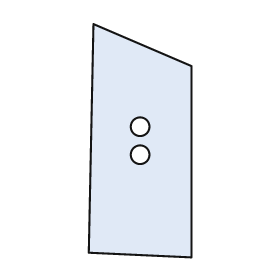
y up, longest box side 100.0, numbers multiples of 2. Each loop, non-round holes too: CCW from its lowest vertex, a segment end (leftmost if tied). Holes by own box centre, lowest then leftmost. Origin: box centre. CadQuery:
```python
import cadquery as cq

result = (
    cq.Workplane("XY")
    .moveTo(22.0, -50.0)
    .lineTo(22.0, 32.0)
    .lineTo(-20.0, 50.0)
    .lineTo(-22.0, -48.0)
    .close()
    .moveTo(0.0, -6.0)
    .circle(4.0)
    .moveTo(0.0, 6.0)
    .circle(4.0)
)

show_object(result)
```